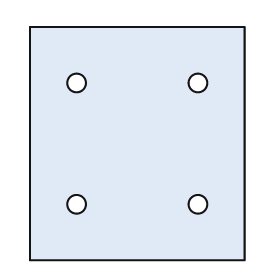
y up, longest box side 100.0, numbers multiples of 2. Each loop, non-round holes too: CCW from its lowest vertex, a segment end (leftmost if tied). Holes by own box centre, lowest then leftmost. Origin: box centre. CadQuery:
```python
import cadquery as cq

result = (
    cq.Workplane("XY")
    .moveTo(-46.0, -50.0)
    .lineTo(46.0, -50.0)
    .lineTo(46.0, 50.0)
    .lineTo(-46.0, 50.0)
    .close()
    .moveTo(-26.0, -26.0)
    .circle(4.0)
    .moveTo(26.0, -26.0)
    .circle(4.0)
    .moveTo(-26.0, 26.0)
    .circle(4.0)
    .moveTo(26.0, 26.0)
    .circle(4.0)
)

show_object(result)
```